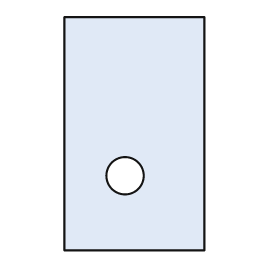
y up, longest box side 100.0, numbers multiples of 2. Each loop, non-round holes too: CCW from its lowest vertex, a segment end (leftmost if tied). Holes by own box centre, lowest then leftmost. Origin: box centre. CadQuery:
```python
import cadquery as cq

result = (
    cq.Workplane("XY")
    .moveTo(-30.0, -50.0)
    .lineTo(30.0, -50.0)
    .lineTo(30.0, 50.0)
    .lineTo(-30.0, 50.0)
    .close()
    .moveTo(-4.0, -18.0)
    .circle(8.0)
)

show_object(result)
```